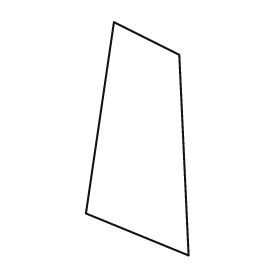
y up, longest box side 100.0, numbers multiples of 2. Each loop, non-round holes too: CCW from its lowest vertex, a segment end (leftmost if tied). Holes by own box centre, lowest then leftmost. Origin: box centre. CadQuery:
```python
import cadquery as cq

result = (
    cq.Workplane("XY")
    .moveTo(22.0, -50.0)
    .lineTo(18.0, 36.0)
    .lineTo(-10.0, 50.0)
    .lineTo(-22.0, -32.0)
    .close()
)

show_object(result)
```